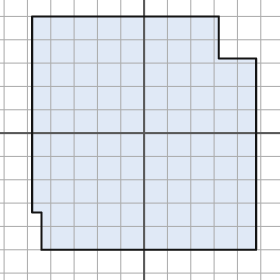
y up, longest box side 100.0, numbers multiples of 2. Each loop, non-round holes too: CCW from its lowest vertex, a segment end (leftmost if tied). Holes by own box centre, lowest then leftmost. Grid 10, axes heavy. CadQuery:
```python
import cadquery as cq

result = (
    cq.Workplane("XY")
    .moveTo(-44.0, -50.0)
    .lineTo(48.0, -50.0)
    .lineTo(48.0, 32.0)
    .lineTo(32.0, 32.0)
    .lineTo(32.0, 50.0)
    .lineTo(-48.0, 50.0)
    .lineTo(-48.0, -34.0)
    .lineTo(-44.0, -34.0)
    .close()
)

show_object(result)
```